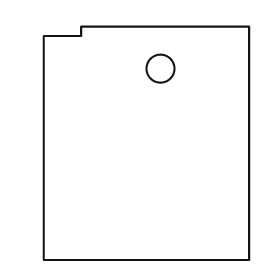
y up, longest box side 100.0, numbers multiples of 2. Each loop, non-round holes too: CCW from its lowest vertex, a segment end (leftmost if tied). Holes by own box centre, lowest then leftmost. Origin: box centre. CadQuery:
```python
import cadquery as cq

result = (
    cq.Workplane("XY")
    .moveTo(-44.0, -50.0)
    .lineTo(44.0, -50.0)
    .lineTo(44.0, 50.0)
    .lineTo(-28.0, 50.0)
    .lineTo(-28.0, 46.0)
    .lineTo(-44.0, 46.0)
    .close()
    .moveTo(6.0, 32.0)
    .circle(6.0)
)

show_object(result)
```